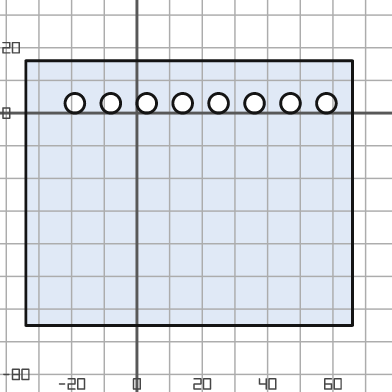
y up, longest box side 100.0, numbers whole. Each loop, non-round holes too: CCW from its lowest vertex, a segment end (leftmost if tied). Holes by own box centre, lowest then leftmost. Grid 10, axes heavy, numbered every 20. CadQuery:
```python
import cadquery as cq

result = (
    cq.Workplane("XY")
    .moveTo(-34.0, -65.0)
    .lineTo(66.0, -65.0)
    .lineTo(66.0, 16.0)
    .lineTo(-34.0, 16.0)
    .close()
    .moveTo(-19.0, 3.0)
    .circle(3.0)
    .moveTo(-8.0, 3.0)
    .circle(3.0)
    .moveTo(3.0, 3.0)
    .circle(3.0)
    .moveTo(14.0, 3.0)
    .circle(3.0)
    .moveTo(25.0, 3.0)
    .circle(3.0)
    .moveTo(36.0, 3.0)
    .circle(3.0)
    .moveTo(47.0, 3.0)
    .circle(3.0)
    .moveTo(58.0, 3.0)
    .circle(3.0)
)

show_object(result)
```